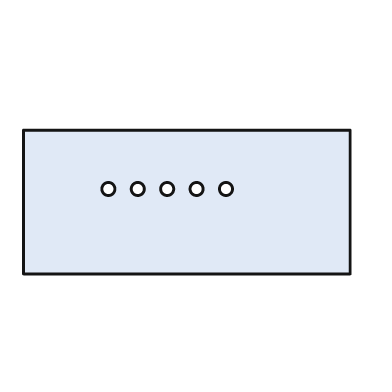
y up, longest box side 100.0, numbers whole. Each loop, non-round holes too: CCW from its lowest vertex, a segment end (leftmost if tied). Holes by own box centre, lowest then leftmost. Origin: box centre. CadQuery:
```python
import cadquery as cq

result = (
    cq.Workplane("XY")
    .moveTo(-50.0, -22.0)
    .lineTo(50.0, -22.0)
    .lineTo(50.0, 22.0)
    .lineTo(-50.0, 22.0)
    .close()
    .moveTo(-24.0, 4.0)
    .circle(2.0)
    .moveTo(-15.0, 4.0)
    .circle(2.0)
    .moveTo(-6.0, 4.0)
    .circle(2.0)
    .moveTo(3.0, 4.0)
    .circle(2.0)
    .moveTo(12.0, 4.0)
    .circle(2.0)
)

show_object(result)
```